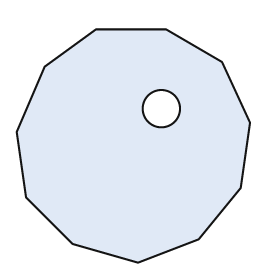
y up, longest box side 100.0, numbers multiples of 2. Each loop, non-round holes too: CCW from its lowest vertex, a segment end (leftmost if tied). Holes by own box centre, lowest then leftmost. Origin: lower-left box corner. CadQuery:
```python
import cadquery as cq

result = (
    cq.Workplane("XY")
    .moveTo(52.0, 0.0)
    .lineTo(78.0, 10.0)
    .lineTo(96.0, 32.0)
    .lineTo(100.0, 60.0)
    .lineTo(88.0, 86.0)
    .lineTo(64.0, 100.0)
    .lineTo(34.0, 100.0)
    .lineTo(12.0, 84.0)
    .lineTo(0.0, 56.0)
    .lineTo(4.0, 28.0)
    .lineTo(24.0, 8.0)
    .close()
    .moveTo(62.0, 66.0)
    .circle(8.0)
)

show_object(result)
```